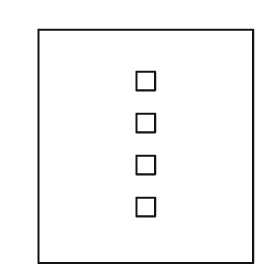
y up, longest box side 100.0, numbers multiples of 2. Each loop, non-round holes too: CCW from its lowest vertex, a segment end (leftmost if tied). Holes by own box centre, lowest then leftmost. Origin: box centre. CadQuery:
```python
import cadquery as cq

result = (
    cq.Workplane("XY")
    .moveTo(-46.0, -50.0)
    .lineTo(46.0, -50.0)
    .lineTo(46.0, 50.0)
    .lineTo(-46.0, 50.0)
    .close()
    .moveTo(-4.0, -30.0)
    .lineTo(4.0, -30.0)
    .lineTo(4.0, -22.0)
    .lineTo(-4.0, -22.0)
    .close()
    .moveTo(-4.0, -12.0)
    .lineTo(4.0, -12.0)
    .lineTo(4.0, -4.0)
    .lineTo(-4.0, -4.0)
    .close()
    .moveTo(-4.0, 6.0)
    .lineTo(4.0, 6.0)
    .lineTo(4.0, 14.0)
    .lineTo(-4.0, 14.0)
    .close()
    .moveTo(-4.0, 24.0)
    .lineTo(4.0, 24.0)
    .lineTo(4.0, 32.0)
    .lineTo(-4.0, 32.0)
    .close()
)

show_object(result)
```